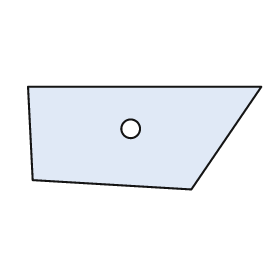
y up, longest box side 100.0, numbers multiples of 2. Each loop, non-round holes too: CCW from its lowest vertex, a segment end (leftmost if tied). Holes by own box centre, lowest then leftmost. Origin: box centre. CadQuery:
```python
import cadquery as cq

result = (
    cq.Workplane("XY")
    .moveTo(20.0, -22.0)
    .lineTo(50.0, 22.0)
    .lineTo(-50.0, 22.0)
    .lineTo(-48.0, -18.0)
    .close()
    .moveTo(-6.0, 4.0)
    .circle(4.0)
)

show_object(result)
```